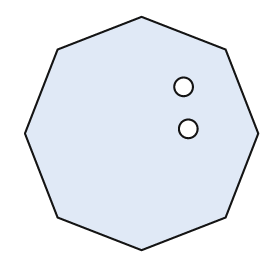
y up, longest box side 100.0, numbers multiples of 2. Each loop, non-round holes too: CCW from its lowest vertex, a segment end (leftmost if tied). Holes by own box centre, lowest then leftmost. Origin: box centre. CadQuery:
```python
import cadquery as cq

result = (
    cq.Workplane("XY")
    .moveTo(0.0, -50.0)
    .lineTo(36.0, -36.0)
    .lineTo(50.0, 0.0)
    .lineTo(36.0, 36.0)
    .lineTo(0.0, 50.0)
    .lineTo(-36.0, 36.0)
    .lineTo(-50.0, 0.0)
    .lineTo(-36.0, -36.0)
    .close()
    .moveTo(20.0, 2.0)
    .circle(4.0)
    .moveTo(18.0, 20.0)
    .circle(4.0)
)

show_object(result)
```